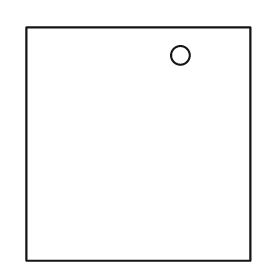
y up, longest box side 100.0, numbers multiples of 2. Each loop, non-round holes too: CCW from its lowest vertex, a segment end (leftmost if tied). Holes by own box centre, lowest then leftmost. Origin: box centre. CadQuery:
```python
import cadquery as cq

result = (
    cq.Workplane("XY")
    .moveTo(-48.0, -50.0)
    .lineTo(48.0, -50.0)
    .lineTo(48.0, 50.0)
    .lineTo(-48.0, 50.0)
    .close()
    .moveTo(18.0, 38.0)
    .circle(4.0)
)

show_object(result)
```